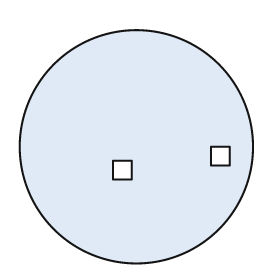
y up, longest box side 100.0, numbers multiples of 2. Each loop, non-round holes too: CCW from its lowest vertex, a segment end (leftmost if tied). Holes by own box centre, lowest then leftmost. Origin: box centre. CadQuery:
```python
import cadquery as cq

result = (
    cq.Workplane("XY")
    .moveTo(0.0, 0.0)
    .circle(50.0)
    .moveTo(-10.0, -14.0)
    .lineTo(-2.0, -14.0)
    .lineTo(-2.0, -6.0)
    .lineTo(-10.0, -6.0)
    .close()
    .moveTo(32.0, -8.0)
    .lineTo(40.0, -8.0)
    .lineTo(40.0, 0.0)
    .lineTo(32.0, 0.0)
    .close()
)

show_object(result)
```